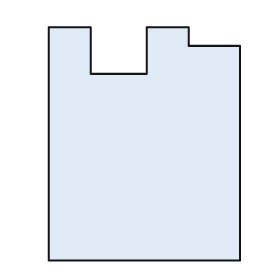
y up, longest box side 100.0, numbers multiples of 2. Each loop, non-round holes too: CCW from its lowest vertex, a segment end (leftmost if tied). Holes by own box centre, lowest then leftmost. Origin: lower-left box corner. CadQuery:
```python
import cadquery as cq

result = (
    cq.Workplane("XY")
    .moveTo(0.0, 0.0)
    .lineTo(82.0, 0.0)
    .lineTo(82.0, 92.0)
    .lineTo(60.0, 92.0)
    .lineTo(60.0, 100.0)
    .lineTo(42.0, 100.0)
    .lineTo(42.0, 80.0)
    .lineTo(18.0, 80.0)
    .lineTo(18.0, 100.0)
    .lineTo(0.0, 100.0)
    .close()
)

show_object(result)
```